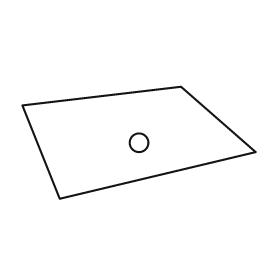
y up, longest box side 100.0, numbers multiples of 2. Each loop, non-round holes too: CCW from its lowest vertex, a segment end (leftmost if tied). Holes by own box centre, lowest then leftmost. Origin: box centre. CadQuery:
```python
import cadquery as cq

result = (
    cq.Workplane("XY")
    .moveTo(-34.0, -24.0)
    .lineTo(50.0, -4.0)
    .lineTo(18.0, 24.0)
    .lineTo(-50.0, 16.0)
    .close()
    .moveTo(0.0, 0.0)
    .circle(4.0)
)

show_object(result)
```